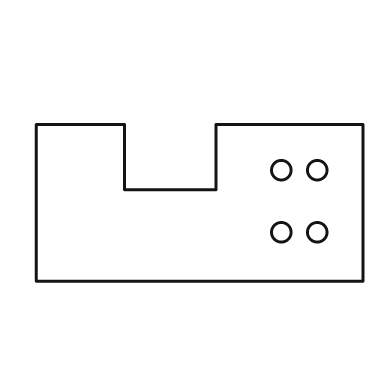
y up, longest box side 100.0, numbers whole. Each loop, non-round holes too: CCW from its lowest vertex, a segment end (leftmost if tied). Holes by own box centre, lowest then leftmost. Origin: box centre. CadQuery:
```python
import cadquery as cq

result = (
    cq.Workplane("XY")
    .moveTo(-50.0, -24.0)
    .lineTo(50.0, -24.0)
    .lineTo(50.0, 24.0)
    .lineTo(5.0, 24.0)
    .lineTo(5.0, 4.0)
    .lineTo(-23.0, 4.0)
    .lineTo(-23.0, 24.0)
    .lineTo(-50.0, 24.0)
    .close()
    .moveTo(25.0, -9.0)
    .circle(3.0)
    .moveTo(36.0, -9.0)
    .circle(3.0)
    .moveTo(25.0, 10.0)
    .circle(3.0)
    .moveTo(36.0, 10.0)
    .circle(3.0)
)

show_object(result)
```